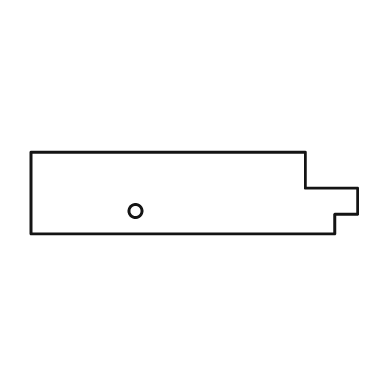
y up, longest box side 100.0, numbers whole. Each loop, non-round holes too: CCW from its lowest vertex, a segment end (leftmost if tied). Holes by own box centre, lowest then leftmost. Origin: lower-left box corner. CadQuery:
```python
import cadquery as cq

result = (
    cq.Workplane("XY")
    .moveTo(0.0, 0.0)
    .lineTo(93.0, 0.0)
    .lineTo(93.0, 6.0)
    .lineTo(100.0, 6.0)
    .lineTo(100.0, 14.0)
    .lineTo(84.0, 14.0)
    .lineTo(84.0, 25.0)
    .lineTo(0.0, 25.0)
    .close()
    .moveTo(32.0, 7.0)
    .circle(2.0)
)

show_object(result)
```